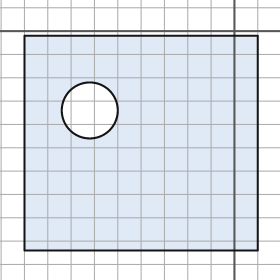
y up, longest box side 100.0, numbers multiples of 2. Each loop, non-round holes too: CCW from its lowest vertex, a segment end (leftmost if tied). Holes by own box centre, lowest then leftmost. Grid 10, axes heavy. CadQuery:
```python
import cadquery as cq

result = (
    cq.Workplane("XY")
    .moveTo(-90.0, -94.0)
    .lineTo(10.0, -94.0)
    .lineTo(10.0, -2.0)
    .lineTo(-90.0, -2.0)
    .close()
    .moveTo(-62.0, -34.0)
    .circle(12.0)
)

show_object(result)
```